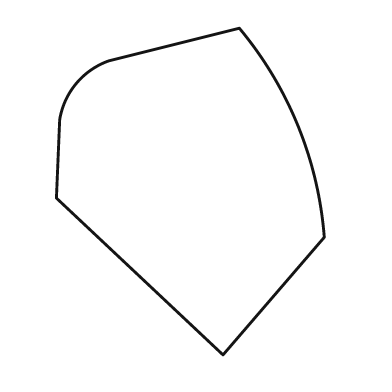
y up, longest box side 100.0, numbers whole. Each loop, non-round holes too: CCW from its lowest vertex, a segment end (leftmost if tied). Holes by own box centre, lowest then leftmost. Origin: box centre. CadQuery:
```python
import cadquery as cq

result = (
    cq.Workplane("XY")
    .moveTo(10.0, -50.0)
    .lineTo(41.0, -14.0)
    .threePointArc((33.0, 20.0), (15.0, 50.0))
    .lineTo(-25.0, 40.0)
    .threePointArc((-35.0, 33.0), (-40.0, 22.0))
    .lineTo(-41.0, -2.0)
    .close()
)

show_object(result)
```